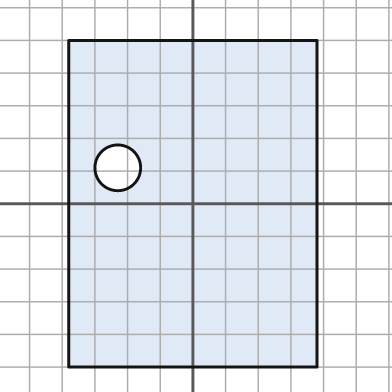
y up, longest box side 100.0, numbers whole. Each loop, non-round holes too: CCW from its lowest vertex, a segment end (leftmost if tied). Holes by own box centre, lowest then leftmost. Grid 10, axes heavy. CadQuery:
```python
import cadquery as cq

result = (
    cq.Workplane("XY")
    .moveTo(-38.0, -50.0)
    .lineTo(38.0, -50.0)
    .lineTo(38.0, 50.0)
    .lineTo(-38.0, 50.0)
    .close()
    .moveTo(-23.0, 11.0)
    .circle(7.0)
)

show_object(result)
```